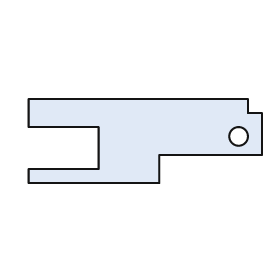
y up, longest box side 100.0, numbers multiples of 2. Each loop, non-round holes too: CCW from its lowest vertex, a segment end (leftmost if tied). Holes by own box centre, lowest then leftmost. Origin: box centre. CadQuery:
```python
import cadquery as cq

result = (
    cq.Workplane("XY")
    .moveTo(-50.0, -18.0)
    .lineTo(6.0, -18.0)
    .lineTo(6.0, -6.0)
    .lineTo(50.0, -6.0)
    .lineTo(50.0, 12.0)
    .lineTo(44.0, 12.0)
    .lineTo(44.0, 18.0)
    .lineTo(-50.0, 18.0)
    .lineTo(-50.0, 6.0)
    .lineTo(-20.0, 6.0)
    .lineTo(-20.0, -12.0)
    .lineTo(-50.0, -12.0)
    .close()
    .moveTo(40.0, 2.0)
    .circle(4.0)
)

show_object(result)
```